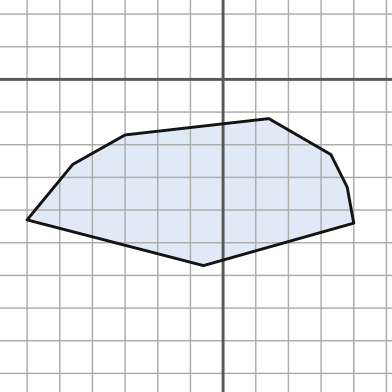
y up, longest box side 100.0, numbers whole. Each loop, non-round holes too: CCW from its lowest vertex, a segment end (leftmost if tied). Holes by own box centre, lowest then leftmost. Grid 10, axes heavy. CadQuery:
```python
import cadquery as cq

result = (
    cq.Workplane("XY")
    .moveTo(-6.0, -57.0)
    .lineTo(40.0, -44.0)
    .lineTo(38.0, -33.0)
    .lineTo(33.0, -23.0)
    .lineTo(14.0, -12.0)
    .lineTo(-30.0, -17.0)
    .lineTo(-46.0, -26.0)
    .lineTo(-60.0, -43.0)
    .close()
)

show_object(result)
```